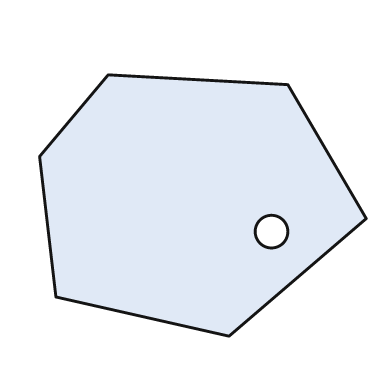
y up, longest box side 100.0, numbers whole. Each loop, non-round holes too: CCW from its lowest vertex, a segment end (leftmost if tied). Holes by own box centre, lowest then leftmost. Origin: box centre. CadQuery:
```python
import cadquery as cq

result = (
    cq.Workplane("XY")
    .moveTo(8.0, -40.0)
    .lineTo(50.0, -4.0)
    .lineTo(26.0, 37.0)
    .lineTo(-29.0, 40.0)
    .lineTo(-50.0, 15.0)
    .lineTo(-45.0, -28.0)
    .close()
    .moveTo(21.0, -8.0)
    .circle(5.0)
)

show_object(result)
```